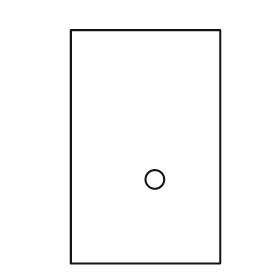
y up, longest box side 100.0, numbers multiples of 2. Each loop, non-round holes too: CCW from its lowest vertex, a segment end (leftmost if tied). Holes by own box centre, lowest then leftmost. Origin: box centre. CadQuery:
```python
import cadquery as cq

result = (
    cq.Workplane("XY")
    .moveTo(-32.0, -50.0)
    .lineTo(32.0, -50.0)
    .lineTo(32.0, 50.0)
    .lineTo(-32.0, 50.0)
    .close()
    .moveTo(4.0, -14.0)
    .circle(4.0)
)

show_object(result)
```